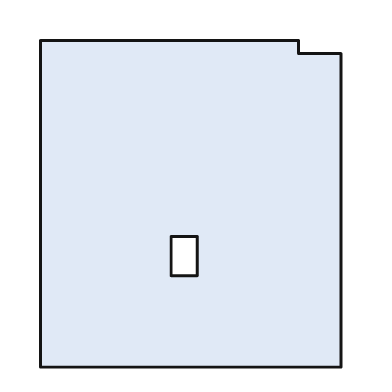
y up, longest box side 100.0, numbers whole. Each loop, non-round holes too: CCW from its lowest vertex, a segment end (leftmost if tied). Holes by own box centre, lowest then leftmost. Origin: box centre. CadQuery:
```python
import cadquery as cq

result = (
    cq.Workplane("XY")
    .moveTo(-46.0, -50.0)
    .lineTo(46.0, -50.0)
    .lineTo(46.0, 46.0)
    .lineTo(33.0, 46.0)
    .lineTo(33.0, 50.0)
    .lineTo(-46.0, 50.0)
    .close()
    .moveTo(-6.0, -22.0)
    .lineTo(2.0, -22.0)
    .lineTo(2.0, -10.0)
    .lineTo(-6.0, -10.0)
    .close()
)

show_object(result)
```